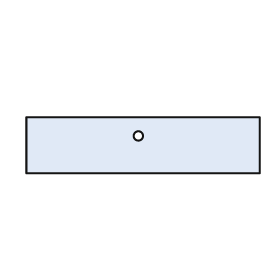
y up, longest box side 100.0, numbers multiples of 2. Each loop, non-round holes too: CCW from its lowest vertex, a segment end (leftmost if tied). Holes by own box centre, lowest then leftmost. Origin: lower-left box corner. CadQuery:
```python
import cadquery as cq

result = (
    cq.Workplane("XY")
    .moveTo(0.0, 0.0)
    .lineTo(100.0, 0.0)
    .lineTo(100.0, 24.0)
    .lineTo(0.0, 24.0)
    .close()
    .moveTo(48.0, 16.0)
    .circle(2.0)
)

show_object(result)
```